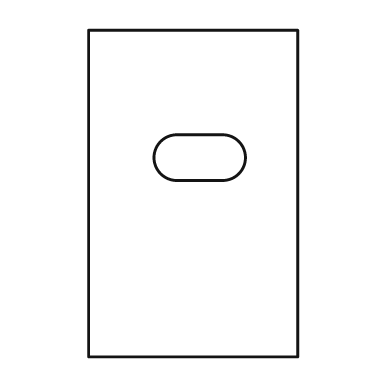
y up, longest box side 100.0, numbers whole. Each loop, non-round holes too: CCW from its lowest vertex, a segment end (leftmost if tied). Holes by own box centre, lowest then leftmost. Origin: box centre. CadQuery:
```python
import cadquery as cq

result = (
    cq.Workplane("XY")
    .moveTo(-32.0, -50.0)
    .lineTo(32.0, -50.0)
    .lineTo(32.0, 50.0)
    .lineTo(-32.0, 50.0)
    .close()
    .moveTo(-5.0, 4.0)
    .lineTo(9.0, 4.0)
    .threePointArc((16.0, 11.0), (9.0, 18.0))
    .lineTo(-5.0, 18.0)
    .threePointArc((-12.0, 11.0), (-5.0, 4.0))
    .close()
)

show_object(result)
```